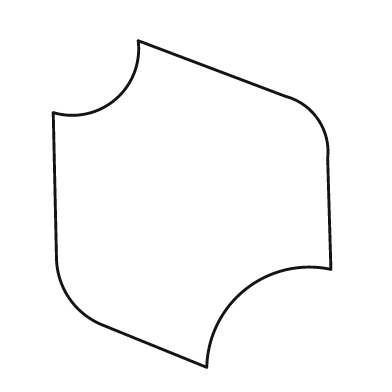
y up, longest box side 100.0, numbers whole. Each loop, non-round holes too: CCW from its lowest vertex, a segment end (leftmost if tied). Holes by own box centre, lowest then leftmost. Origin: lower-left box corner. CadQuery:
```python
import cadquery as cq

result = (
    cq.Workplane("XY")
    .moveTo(47.0, 0.0)
    .threePointArc((59.0, 24.0), (85.0, 30.0))
    .lineTo(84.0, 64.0)
    .threePointArc((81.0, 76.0), (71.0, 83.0))
    .lineTo(26.0, 100.0)
    .threePointArc((19.0, 82.0), (0.0, 78.0))
    .lineTo(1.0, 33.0)
    .threePointArc((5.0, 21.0), (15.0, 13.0))
    .close()
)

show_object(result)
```